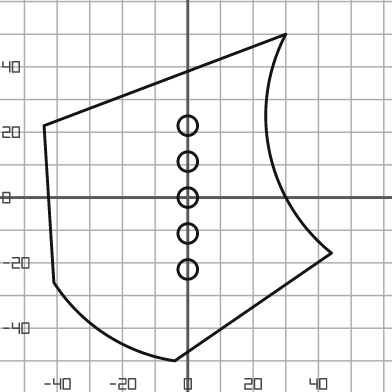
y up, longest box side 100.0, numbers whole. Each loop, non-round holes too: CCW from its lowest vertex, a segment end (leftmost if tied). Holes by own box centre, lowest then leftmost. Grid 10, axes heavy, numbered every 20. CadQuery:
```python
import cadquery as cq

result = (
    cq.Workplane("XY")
    .moveTo(-4.0, -50.0)
    .lineTo(44.0, -17.0)
    .threePointArc((25.0, 14.0), (30.0, 50.0))
    .lineTo(-44.0, 22.0)
    .lineTo(-41.0, -26.0)
    .threePointArc((-25.0, -42.0), (-4.0, -50.0))
    .close()
    .moveTo(0.0, -22.0)
    .circle(3.0)
    .moveTo(0.0, -11.0)
    .circle(3.0)
    .moveTo(0.0, 0.0)
    .circle(3.0)
    .moveTo(0.0, 11.0)
    .circle(3.0)
    .moveTo(0.0, 22.0)
    .circle(3.0)
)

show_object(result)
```